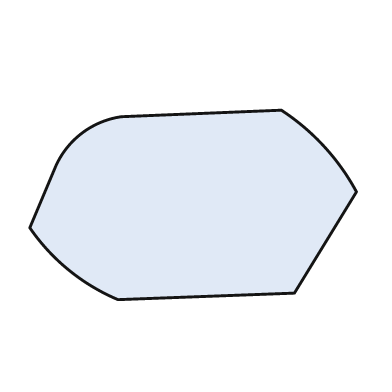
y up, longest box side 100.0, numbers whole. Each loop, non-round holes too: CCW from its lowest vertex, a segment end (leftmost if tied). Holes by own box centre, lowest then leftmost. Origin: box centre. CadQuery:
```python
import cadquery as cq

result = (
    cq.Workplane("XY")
    .moveTo(-23.0, -29.0)
    .lineTo(31.0, -27.0)
    .lineTo(50.0, 4.0)
    .threePointArc((40.0, 18.0), (27.0, 29.0))
    .lineTo(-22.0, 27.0)
    .threePointArc((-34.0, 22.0), (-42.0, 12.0))
    .lineTo(-50.0, -7.0)
    .threePointArc((-38.0, -20.0), (-23.0, -29.0))
    .close()
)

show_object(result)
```